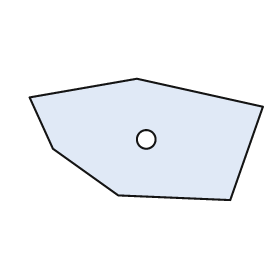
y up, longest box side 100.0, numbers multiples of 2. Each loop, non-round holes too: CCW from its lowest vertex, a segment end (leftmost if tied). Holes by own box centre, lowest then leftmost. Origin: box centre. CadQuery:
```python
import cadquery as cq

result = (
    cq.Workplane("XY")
    .moveTo(36.0, -26.0)
    .lineTo(50.0, 14.0)
    .lineTo(-4.0, 26.0)
    .lineTo(-50.0, 18.0)
    .lineTo(-40.0, -4.0)
    .lineTo(-12.0, -24.0)
    .close()
    .moveTo(0.0, 0.0)
    .circle(4.0)
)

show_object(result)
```